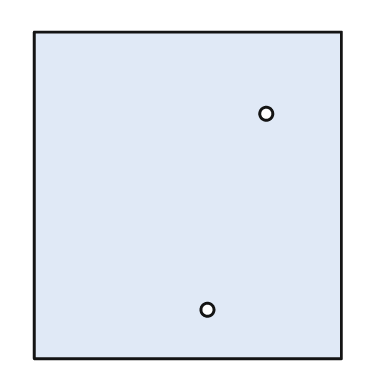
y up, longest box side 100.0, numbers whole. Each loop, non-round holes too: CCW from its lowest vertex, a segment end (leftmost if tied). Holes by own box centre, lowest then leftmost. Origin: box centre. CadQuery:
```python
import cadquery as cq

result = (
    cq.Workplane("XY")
    .moveTo(-47.0, -50.0)
    .lineTo(47.0, -50.0)
    .lineTo(47.0, 50.0)
    .lineTo(-47.0, 50.0)
    .close()
    .moveTo(6.0, -35.0)
    .circle(2.0)
    .moveTo(24.0, 25.0)
    .circle(2.0)
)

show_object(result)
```